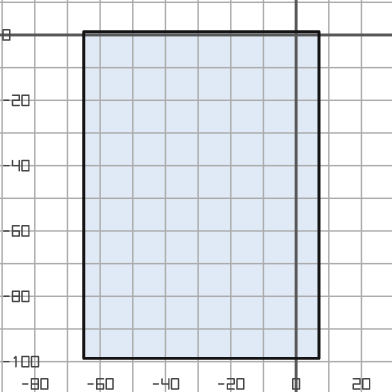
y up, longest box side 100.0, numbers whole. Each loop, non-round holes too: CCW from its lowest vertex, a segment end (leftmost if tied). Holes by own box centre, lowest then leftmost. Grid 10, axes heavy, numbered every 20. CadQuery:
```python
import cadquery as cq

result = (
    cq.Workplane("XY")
    .moveTo(-65.0, -99.0)
    .lineTo(7.0, -99.0)
    .lineTo(7.0, 1.0)
    .lineTo(-65.0, 1.0)
    .close()
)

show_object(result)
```